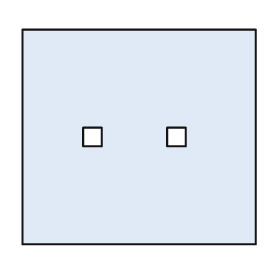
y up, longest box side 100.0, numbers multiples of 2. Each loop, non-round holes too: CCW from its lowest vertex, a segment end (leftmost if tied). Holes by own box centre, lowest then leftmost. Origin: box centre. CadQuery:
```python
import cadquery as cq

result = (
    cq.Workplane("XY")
    .moveTo(-50.0, -46.0)
    .lineTo(50.0, -46.0)
    .lineTo(50.0, 46.0)
    .lineTo(-50.0, 46.0)
    .close()
    .moveTo(-24.0, -4.0)
    .lineTo(-16.0, -4.0)
    .lineTo(-16.0, 4.0)
    .lineTo(-24.0, 4.0)
    .close()
    .moveTo(12.0, -4.0)
    .lineTo(20.0, -4.0)
    .lineTo(20.0, 4.0)
    .lineTo(12.0, 4.0)
    .close()
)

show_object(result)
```